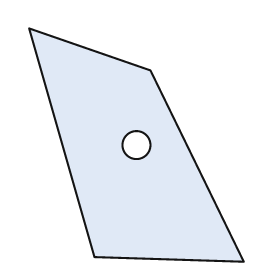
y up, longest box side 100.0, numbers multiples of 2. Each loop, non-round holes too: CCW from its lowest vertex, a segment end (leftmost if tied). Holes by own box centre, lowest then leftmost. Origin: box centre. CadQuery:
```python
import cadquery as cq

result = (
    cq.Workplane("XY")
    .moveTo(46.0, -50.0)
    .lineTo(6.0, 32.0)
    .lineTo(-46.0, 50.0)
    .lineTo(-18.0, -48.0)
    .close()
    .moveTo(0.0, 0.0)
    .circle(6.0)
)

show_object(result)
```